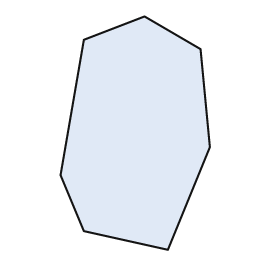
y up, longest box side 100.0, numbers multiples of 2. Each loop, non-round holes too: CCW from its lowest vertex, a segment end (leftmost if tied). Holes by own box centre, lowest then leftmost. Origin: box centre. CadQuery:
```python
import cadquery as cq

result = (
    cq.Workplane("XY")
    .moveTo(14.0, -50.0)
    .lineTo(32.0, -6.0)
    .lineTo(28.0, 36.0)
    .lineTo(4.0, 50.0)
    .lineTo(-22.0, 40.0)
    .lineTo(-32.0, -18.0)
    .lineTo(-22.0, -42.0)
    .close()
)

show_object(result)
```